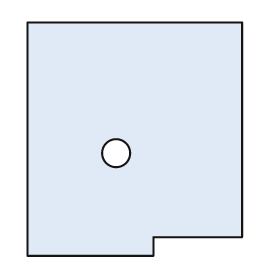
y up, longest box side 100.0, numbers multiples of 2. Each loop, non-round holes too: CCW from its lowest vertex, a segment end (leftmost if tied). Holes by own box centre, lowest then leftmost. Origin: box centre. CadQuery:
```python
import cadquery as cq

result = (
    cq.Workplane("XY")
    .moveTo(-46.0, -50.0)
    .lineTo(8.0, -50.0)
    .lineTo(8.0, -42.0)
    .lineTo(46.0, -42.0)
    .lineTo(46.0, 50.0)
    .lineTo(-46.0, 50.0)
    .close()
    .moveTo(-8.0, -6.0)
    .circle(6.0)
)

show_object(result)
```